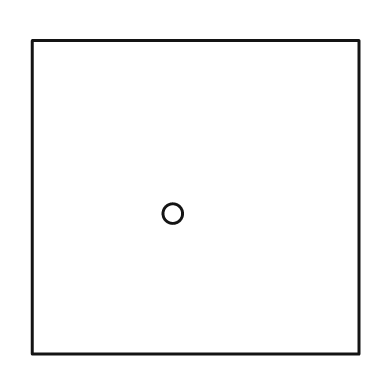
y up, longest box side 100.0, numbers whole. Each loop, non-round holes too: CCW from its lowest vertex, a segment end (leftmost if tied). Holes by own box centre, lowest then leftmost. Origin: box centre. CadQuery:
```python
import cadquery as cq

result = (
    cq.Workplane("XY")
    .moveTo(-50.0, -48.0)
    .lineTo(50.0, -48.0)
    .lineTo(50.0, 48.0)
    .lineTo(-50.0, 48.0)
    .close()
    .moveTo(-7.0, -5.0)
    .circle(3.0)
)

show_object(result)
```